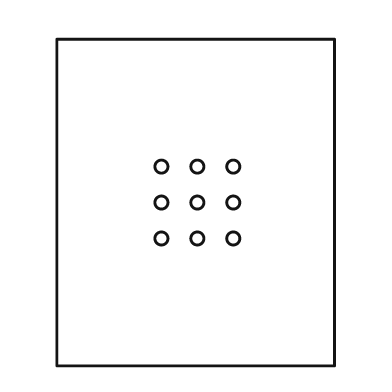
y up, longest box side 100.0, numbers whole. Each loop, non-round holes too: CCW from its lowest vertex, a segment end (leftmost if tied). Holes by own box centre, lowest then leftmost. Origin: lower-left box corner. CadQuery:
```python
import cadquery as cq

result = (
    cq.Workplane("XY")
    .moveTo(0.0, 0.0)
    .lineTo(85.0, 0.0)
    .lineTo(85.0, 100.0)
    .lineTo(0.0, 100.0)
    .close()
    .moveTo(32.0, 39.0)
    .circle(2.0)
    .moveTo(43.0, 39.0)
    .circle(2.0)
    .moveTo(54.0, 39.0)
    .circle(2.0)
    .moveTo(32.0, 50.0)
    .circle(2.0)
    .moveTo(43.0, 50.0)
    .circle(2.0)
    .moveTo(54.0, 50.0)
    .circle(2.0)
    .moveTo(32.0, 61.0)
    .circle(2.0)
    .moveTo(43.0, 61.0)
    .circle(2.0)
    .moveTo(54.0, 61.0)
    .circle(2.0)
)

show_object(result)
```